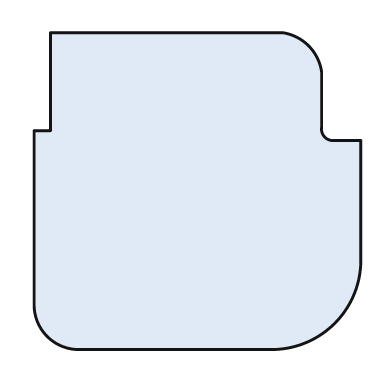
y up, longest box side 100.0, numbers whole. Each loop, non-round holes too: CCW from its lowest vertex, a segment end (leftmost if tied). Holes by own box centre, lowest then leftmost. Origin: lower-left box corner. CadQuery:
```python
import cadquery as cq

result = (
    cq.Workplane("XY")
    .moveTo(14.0, 0.0)
    .lineTo(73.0, 0.0)
    .threePointArc((92.0, 8.0), (100.0, 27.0))
    .lineTo(100.0, 64.0)
    .lineTo(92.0, 64.0)
    .threePointArc((89.0, 65.0), (88.0, 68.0))
    .lineTo(88.0, 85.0)
    .threePointArc((84.0, 93.0), (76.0, 97.0))
    .lineTo(5.0, 97.0)
    .lineTo(5.0, 67.0)
    .lineTo(0.0, 67.0)
    .lineTo(0.0, 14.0)
    .threePointArc((4.0, 4.0), (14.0, 0.0))
    .close()
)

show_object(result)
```